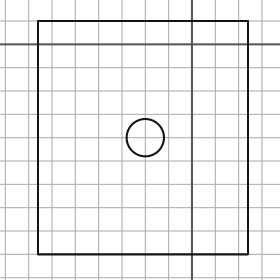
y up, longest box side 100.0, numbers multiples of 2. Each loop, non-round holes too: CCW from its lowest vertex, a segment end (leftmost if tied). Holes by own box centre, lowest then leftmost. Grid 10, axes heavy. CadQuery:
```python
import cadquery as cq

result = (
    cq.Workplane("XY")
    .moveTo(-66.0, -90.0)
    .lineTo(24.0, -90.0)
    .lineTo(24.0, 10.0)
    .lineTo(-66.0, 10.0)
    .close()
    .moveTo(-20.0, -40.0)
    .circle(8.0)
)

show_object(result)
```